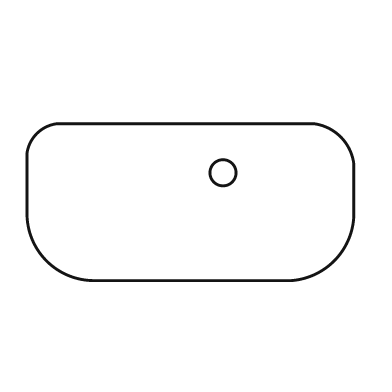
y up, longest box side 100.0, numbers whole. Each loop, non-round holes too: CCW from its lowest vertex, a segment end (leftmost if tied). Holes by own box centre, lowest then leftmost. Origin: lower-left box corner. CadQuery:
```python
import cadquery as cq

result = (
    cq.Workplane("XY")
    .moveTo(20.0, 0.0)
    .lineTo(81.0, 0.0)
    .threePointArc((94.0, 6.0), (100.0, 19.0))
    .lineTo(100.0, 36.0)
    .threePointArc((96.0, 44.0), (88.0, 48.0))
    .lineTo(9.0, 48.0)
    .threePointArc((3.0, 45.0), (0.0, 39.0))
    .lineTo(0.0, 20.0)
    .threePointArc((6.0, 6.0), (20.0, 0.0))
    .close()
    .moveTo(60.0, 33.0)
    .circle(4.0)
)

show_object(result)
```